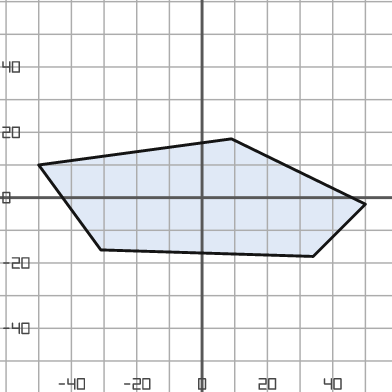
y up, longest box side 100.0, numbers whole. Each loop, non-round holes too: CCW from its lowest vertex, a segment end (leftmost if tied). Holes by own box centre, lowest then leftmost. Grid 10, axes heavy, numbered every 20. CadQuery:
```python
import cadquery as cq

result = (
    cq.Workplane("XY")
    .moveTo(34.0, -18.0)
    .lineTo(50.0, -2.0)
    .lineTo(9.0, 18.0)
    .lineTo(-50.0, 10.0)
    .lineTo(-31.0, -16.0)
    .close()
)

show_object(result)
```